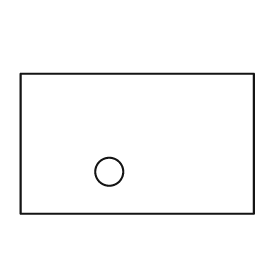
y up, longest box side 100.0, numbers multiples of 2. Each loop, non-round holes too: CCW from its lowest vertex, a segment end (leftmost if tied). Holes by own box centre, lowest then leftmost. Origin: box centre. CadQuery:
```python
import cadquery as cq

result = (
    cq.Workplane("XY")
    .moveTo(-50.0, -30.0)
    .lineTo(50.0, -30.0)
    .lineTo(50.0, 30.0)
    .lineTo(-50.0, 30.0)
    .close()
    .moveTo(-12.0, -12.0)
    .circle(6.0)
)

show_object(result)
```